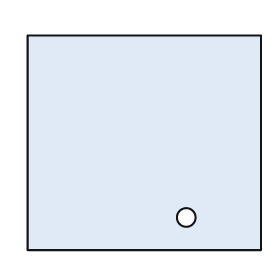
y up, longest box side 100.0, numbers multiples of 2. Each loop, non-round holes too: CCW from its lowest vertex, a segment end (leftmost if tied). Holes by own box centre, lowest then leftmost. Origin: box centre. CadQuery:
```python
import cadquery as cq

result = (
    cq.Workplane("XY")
    .moveTo(-50.0, -46.0)
    .lineTo(50.0, -46.0)
    .lineTo(50.0, 46.0)
    .lineTo(-50.0, 46.0)
    .close()
    .moveTo(18.0, -32.0)
    .circle(4.0)
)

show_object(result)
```